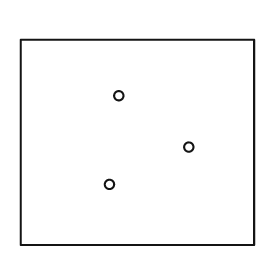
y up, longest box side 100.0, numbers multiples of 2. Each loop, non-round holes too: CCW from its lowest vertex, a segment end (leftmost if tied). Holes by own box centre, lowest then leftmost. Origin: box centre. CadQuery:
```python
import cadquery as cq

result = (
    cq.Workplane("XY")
    .moveTo(-50.0, -44.0)
    .lineTo(50.0, -44.0)
    .lineTo(50.0, 44.0)
    .lineTo(-50.0, 44.0)
    .close()
    .moveTo(-12.0, -18.0)
    .circle(2.0)
    .moveTo(22.0, -2.0)
    .circle(2.0)
    .moveTo(-8.0, 20.0)
    .circle(2.0)
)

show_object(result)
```